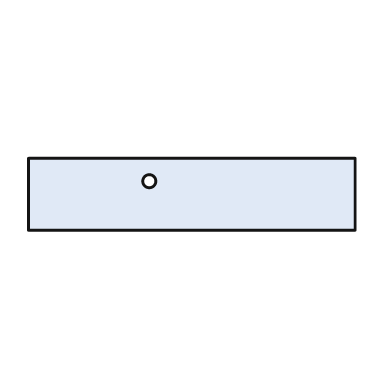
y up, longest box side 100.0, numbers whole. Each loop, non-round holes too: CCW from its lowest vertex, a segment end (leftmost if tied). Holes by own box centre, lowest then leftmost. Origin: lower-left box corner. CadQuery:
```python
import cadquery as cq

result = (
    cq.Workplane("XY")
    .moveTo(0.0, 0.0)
    .lineTo(100.0, 0.0)
    .lineTo(100.0, 22.0)
    .lineTo(0.0, 22.0)
    .close()
    .moveTo(37.0, 15.0)
    .circle(2.0)
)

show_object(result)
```